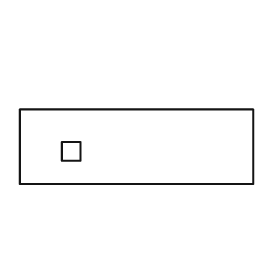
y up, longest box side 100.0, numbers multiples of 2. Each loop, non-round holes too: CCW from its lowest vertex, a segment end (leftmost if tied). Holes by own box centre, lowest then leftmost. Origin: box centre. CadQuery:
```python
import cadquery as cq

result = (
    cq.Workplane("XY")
    .moveTo(-50.0, -16.0)
    .lineTo(50.0, -16.0)
    .lineTo(50.0, 16.0)
    .lineTo(-50.0, 16.0)
    .close()
    .moveTo(-32.0, -6.0)
    .lineTo(-24.0, -6.0)
    .lineTo(-24.0, 2.0)
    .lineTo(-32.0, 2.0)
    .close()
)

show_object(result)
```